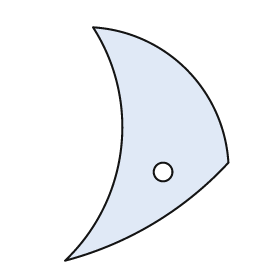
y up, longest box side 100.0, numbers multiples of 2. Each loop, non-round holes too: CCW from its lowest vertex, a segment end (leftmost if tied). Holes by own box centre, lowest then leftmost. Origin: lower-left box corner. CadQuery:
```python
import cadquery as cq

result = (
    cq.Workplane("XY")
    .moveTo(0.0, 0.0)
    .threePointArc((38.0, 16.0), (70.0, 42.0))
    .threePointArc((52.0, 82.0), (12.0, 100.0))
    .threePointArc((24.0, 48.0), (0.0, 0.0))
    .close()
    .moveTo(42.0, 38.0)
    .circle(4.0)
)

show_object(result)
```